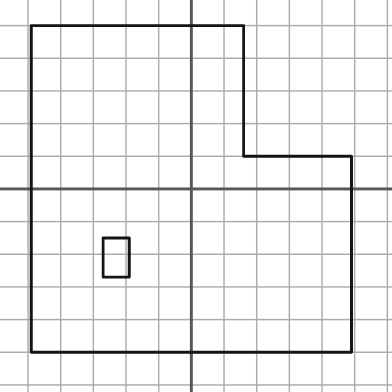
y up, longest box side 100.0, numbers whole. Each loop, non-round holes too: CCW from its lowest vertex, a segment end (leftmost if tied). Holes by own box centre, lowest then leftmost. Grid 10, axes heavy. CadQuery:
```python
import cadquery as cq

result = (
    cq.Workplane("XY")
    .moveTo(-49.0, -50.0)
    .lineTo(49.0, -50.0)
    .lineTo(49.0, 10.0)
    .lineTo(16.0, 10.0)
    .lineTo(16.0, 50.0)
    .lineTo(-49.0, 50.0)
    .close()
    .moveTo(-27.0, -27.0)
    .lineTo(-19.0, -27.0)
    .lineTo(-19.0, -15.0)
    .lineTo(-27.0, -15.0)
    .close()
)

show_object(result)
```